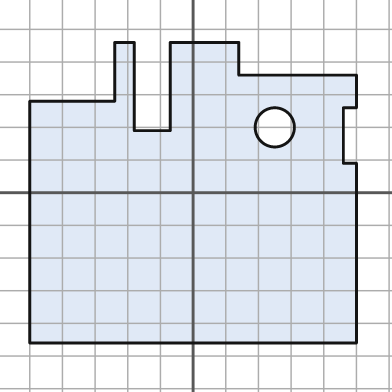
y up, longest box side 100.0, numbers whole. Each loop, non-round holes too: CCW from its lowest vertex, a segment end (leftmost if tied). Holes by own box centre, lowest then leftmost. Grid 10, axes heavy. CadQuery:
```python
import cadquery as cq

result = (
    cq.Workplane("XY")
    .moveTo(-50.0, -46.0)
    .lineTo(50.0, -46.0)
    .lineTo(50.0, 9.0)
    .lineTo(46.0, 9.0)
    .lineTo(46.0, 26.0)
    .lineTo(50.0, 26.0)
    .lineTo(50.0, 36.0)
    .lineTo(14.0, 36.0)
    .lineTo(14.0, 46.0)
    .lineTo(-7.0, 46.0)
    .lineTo(-7.0, 19.0)
    .lineTo(-18.0, 19.0)
    .lineTo(-18.0, 46.0)
    .lineTo(-24.0, 46.0)
    .lineTo(-24.0, 28.0)
    .lineTo(-50.0, 28.0)
    .close()
    .moveTo(25.0, 20.0)
    .circle(6.0)
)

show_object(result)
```